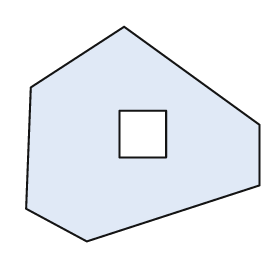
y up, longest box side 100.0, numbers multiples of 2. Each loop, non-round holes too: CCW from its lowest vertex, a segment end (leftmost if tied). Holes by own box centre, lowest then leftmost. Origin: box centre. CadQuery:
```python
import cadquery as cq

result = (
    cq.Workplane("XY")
    .moveTo(-24.0, -46.0)
    .lineTo(50.0, -22.0)
    .lineTo(50.0, 4.0)
    .lineTo(-8.0, 46.0)
    .lineTo(-48.0, 20.0)
    .lineTo(-50.0, -32.0)
    .close()
    .moveTo(-10.0, -10.0)
    .lineTo(10.0, -10.0)
    .lineTo(10.0, 10.0)
    .lineTo(-10.0, 10.0)
    .close()
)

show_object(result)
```